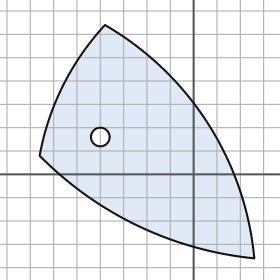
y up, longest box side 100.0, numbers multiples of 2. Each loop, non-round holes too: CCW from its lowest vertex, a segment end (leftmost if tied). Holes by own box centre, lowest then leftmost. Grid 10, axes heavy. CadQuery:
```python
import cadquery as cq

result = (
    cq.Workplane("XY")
    .moveTo(26.0, -36.0)
    .threePointArc((6.0, 22.0), (-38.0, 64.0))
    .threePointArc((-56.0, 38.0), (-66.0, 8.0))
    .threePointArc((-24.0, -22.0), (26.0, -36.0))
    .close()
    .moveTo(-40.0, 16.0)
    .circle(4.0)
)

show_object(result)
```